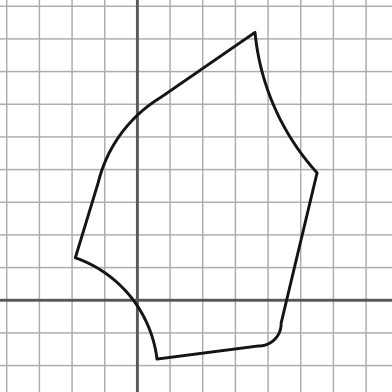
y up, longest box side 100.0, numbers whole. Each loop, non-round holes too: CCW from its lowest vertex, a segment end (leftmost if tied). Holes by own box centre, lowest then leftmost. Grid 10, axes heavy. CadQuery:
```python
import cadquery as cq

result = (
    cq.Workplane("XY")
    .moveTo(6.0, -18.0)
    .lineTo(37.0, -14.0)
    .threePointArc((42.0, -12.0), (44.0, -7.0))
    .lineTo(55.0, 39.0)
    .threePointArc((42.0, 59.0), (36.0, 82.0))
    .lineTo(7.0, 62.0)
    .threePointArc((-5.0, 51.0), (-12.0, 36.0))
    .lineTo(-19.0, 13.0)
    .threePointArc((-2.0, 1.0), (6.0, -18.0))
    .close()
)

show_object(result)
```